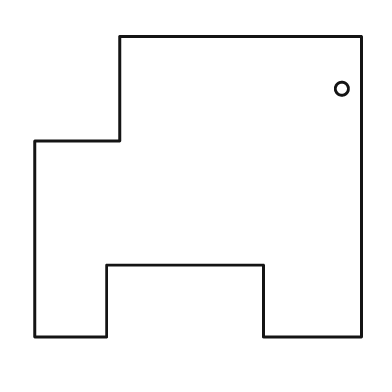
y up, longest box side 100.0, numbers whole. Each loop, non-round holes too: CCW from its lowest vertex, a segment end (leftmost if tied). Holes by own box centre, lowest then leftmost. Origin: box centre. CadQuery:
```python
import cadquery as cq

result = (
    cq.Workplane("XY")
    .moveTo(-50.0, -46.0)
    .lineTo(-28.0, -46.0)
    .lineTo(-28.0, -24.0)
    .lineTo(20.0, -24.0)
    .lineTo(20.0, -46.0)
    .lineTo(50.0, -46.0)
    .lineTo(50.0, 46.0)
    .lineTo(-24.0, 46.0)
    .lineTo(-24.0, 14.0)
    .lineTo(-50.0, 14.0)
    .close()
    .moveTo(44.0, 30.0)
    .circle(2.0)
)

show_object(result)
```